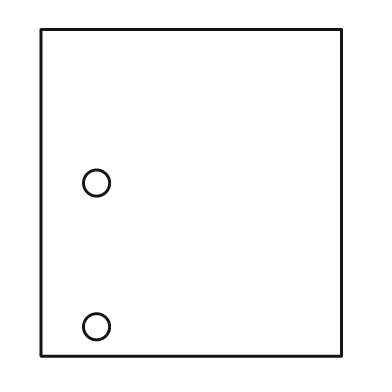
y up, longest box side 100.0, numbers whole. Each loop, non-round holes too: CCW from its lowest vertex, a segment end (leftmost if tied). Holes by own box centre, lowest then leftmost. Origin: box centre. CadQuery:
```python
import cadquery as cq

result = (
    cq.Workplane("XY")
    .moveTo(-46.0, -50.0)
    .lineTo(46.0, -50.0)
    .lineTo(46.0, 50.0)
    .lineTo(-46.0, 50.0)
    .close()
    .moveTo(-29.0, -41.0)
    .circle(4.0)
    .moveTo(-29.0, 3.0)
    .circle(4.0)
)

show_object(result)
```